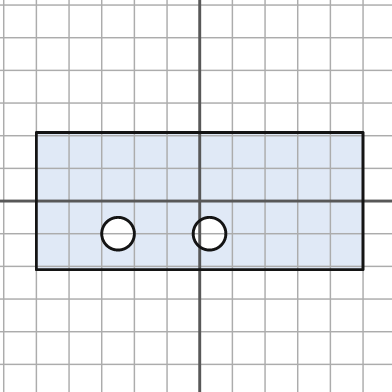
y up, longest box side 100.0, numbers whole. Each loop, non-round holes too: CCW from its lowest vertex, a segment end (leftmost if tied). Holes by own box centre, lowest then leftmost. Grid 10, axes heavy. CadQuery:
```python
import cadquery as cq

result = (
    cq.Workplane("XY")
    .moveTo(-50.0, -21.0)
    .lineTo(50.0, -21.0)
    .lineTo(50.0, 21.0)
    .lineTo(-50.0, 21.0)
    .close()
    .moveTo(-25.0, -10.0)
    .circle(5.0)
    .moveTo(3.0, -10.0)
    .circle(5.0)
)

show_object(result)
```